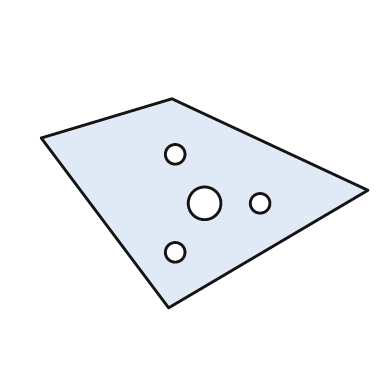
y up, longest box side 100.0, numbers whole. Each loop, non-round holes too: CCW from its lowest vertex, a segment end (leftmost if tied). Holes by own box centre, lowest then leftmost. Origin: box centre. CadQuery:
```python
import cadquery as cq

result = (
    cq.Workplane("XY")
    .moveTo(-11.0, -32.0)
    .lineTo(50.0, 4.0)
    .lineTo(-10.0, 32.0)
    .lineTo(-50.0, 20.0)
    .close()
    .moveTo(-9.0, -15.0)
    .circle(3.0)
    .moveTo(0.0, 0.0)
    .circle(5.0)
    .moveTo(17.0, 0.0)
    .circle(3.0)
    .moveTo(-9.0, 15.0)
    .circle(3.0)
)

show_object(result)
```